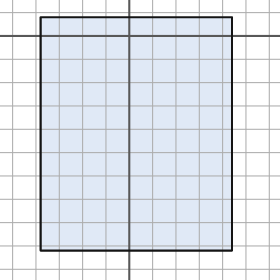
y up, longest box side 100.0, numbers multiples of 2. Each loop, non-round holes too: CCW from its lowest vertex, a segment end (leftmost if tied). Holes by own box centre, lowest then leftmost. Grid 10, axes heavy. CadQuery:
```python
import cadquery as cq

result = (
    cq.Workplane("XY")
    .moveTo(-38.0, -92.0)
    .lineTo(44.0, -92.0)
    .lineTo(44.0, 8.0)
    .lineTo(-38.0, 8.0)
    .close()
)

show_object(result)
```